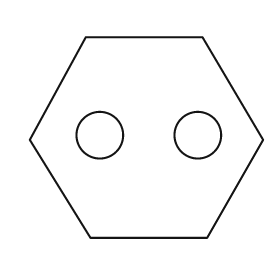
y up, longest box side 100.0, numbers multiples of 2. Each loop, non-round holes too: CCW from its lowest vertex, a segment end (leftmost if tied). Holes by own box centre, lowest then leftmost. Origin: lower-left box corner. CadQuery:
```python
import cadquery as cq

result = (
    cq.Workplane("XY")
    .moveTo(26.0, 0.0)
    .lineTo(76.0, 0.0)
    .lineTo(100.0, 42.0)
    .lineTo(74.0, 86.0)
    .lineTo(24.0, 86.0)
    .lineTo(0.0, 42.0)
    .close()
    .moveTo(30.0, 44.0)
    .circle(10.0)
    .moveTo(72.0, 44.0)
    .circle(10.0)
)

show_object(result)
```